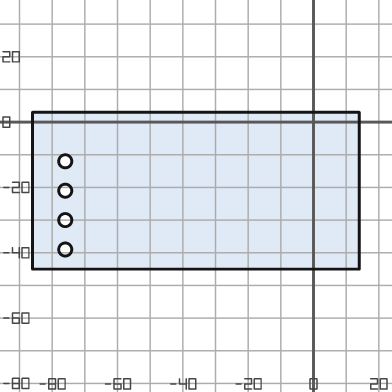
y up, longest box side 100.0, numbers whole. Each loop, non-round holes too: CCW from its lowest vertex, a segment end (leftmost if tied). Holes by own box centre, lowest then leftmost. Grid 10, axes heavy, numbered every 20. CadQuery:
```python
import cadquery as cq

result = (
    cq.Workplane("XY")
    .moveTo(-86.0, -45.0)
    .lineTo(14.0, -45.0)
    .lineTo(14.0, 3.0)
    .lineTo(-86.0, 3.0)
    .close()
    .moveTo(-76.0, -39.0)
    .circle(2.0)
    .moveTo(-76.0, -30.0)
    .circle(2.0)
    .moveTo(-76.0, -21.0)
    .circle(2.0)
    .moveTo(-76.0, -12.0)
    .circle(2.0)
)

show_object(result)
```